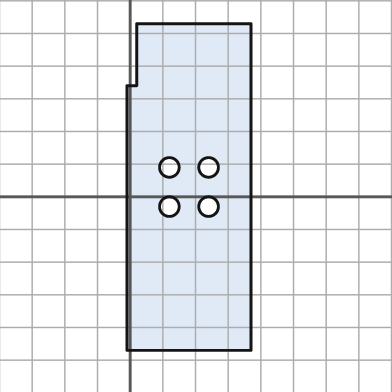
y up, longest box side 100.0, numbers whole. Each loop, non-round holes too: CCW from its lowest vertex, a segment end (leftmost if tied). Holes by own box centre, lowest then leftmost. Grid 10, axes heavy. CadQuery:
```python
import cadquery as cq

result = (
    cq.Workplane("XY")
    .moveTo(-1.0, -47.0)
    .lineTo(37.0, -47.0)
    .lineTo(37.0, 53.0)
    .lineTo(2.0, 53.0)
    .lineTo(2.0, 34.0)
    .lineTo(-1.0, 34.0)
    .close()
    .moveTo(12.0, -3.0)
    .circle(3.0)
    .moveTo(24.0, -3.0)
    .circle(3.0)
    .moveTo(12.0, 9.0)
    .circle(3.0)
    .moveTo(24.0, 9.0)
    .circle(3.0)
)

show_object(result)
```